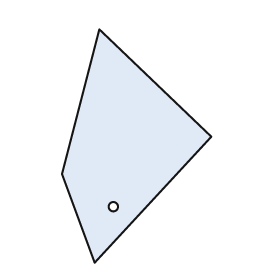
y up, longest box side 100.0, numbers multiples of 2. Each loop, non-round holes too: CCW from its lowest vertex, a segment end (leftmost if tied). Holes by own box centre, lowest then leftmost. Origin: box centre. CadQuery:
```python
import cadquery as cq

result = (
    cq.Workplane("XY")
    .moveTo(-18.0, -50.0)
    .lineTo(32.0, 4.0)
    .lineTo(-16.0, 50.0)
    .lineTo(-32.0, -12.0)
    .close()
    .moveTo(-10.0, -26.0)
    .circle(2.0)
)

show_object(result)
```